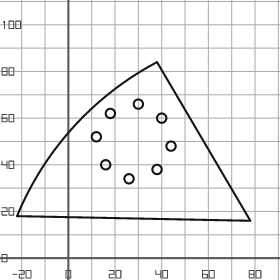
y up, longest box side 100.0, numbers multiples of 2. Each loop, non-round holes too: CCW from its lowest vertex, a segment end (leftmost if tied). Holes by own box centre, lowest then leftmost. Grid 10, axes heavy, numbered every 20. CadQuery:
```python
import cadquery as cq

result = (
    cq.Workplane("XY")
    .moveTo(78.0, 16.0)
    .lineTo(38.0, 84.0)
    .threePointArc((2.0, 56.0), (-22.0, 18.0))
    .close()
    .moveTo(26.0, 34.0)
    .circle(2.0)
    .moveTo(38.0, 38.0)
    .circle(2.0)
    .moveTo(16.0, 40.0)
    .circle(2.0)
    .moveTo(44.0, 48.0)
    .circle(2.0)
    .moveTo(12.0, 52.0)
    .circle(2.0)
    .moveTo(40.0, 60.0)
    .circle(2.0)
    .moveTo(18.0, 62.0)
    .circle(2.0)
    .moveTo(30.0, 66.0)
    .circle(2.0)
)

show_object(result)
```